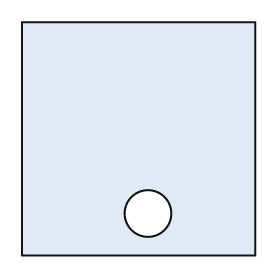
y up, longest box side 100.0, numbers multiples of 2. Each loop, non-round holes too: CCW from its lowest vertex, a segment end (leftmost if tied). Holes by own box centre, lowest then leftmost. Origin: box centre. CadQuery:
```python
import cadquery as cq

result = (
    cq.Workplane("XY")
    .moveTo(-50.0, -50.0)
    .lineTo(50.0, -50.0)
    .lineTo(50.0, 50.0)
    .lineTo(-50.0, 50.0)
    .close()
    .moveTo(4.0, -32.0)
    .circle(10.0)
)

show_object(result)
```